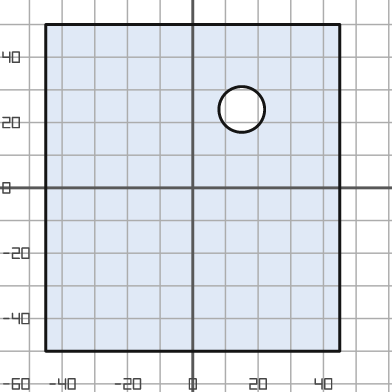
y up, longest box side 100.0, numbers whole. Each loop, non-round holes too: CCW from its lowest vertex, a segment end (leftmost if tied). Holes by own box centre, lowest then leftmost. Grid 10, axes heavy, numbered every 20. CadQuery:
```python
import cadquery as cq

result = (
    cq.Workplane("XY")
    .moveTo(-45.0, -50.0)
    .lineTo(45.0, -50.0)
    .lineTo(45.0, 50.0)
    .lineTo(-45.0, 50.0)
    .close()
    .moveTo(15.0, 24.0)
    .circle(7.0)
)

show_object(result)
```